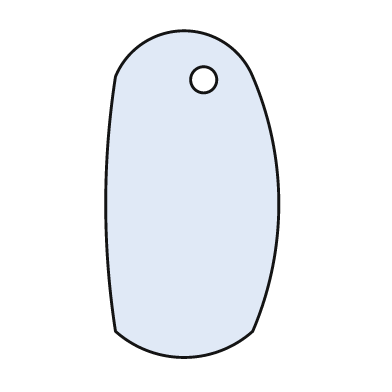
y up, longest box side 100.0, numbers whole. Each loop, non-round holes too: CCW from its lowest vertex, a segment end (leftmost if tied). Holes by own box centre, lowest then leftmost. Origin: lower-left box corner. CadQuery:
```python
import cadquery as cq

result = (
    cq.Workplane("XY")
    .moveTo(3.0, 8.0)
    .threePointArc((24.0, 0.0), (45.0, 8.0))
    .threePointArc((53.0, 47.0), (45.0, 86.0))
    .threePointArc((24.0, 100.0), (3.0, 86.0))
    .threePointArc((0.0, 47.0), (3.0, 8.0))
    .close()
    .moveTo(30.0, 85.0)
    .circle(4.0)
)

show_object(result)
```